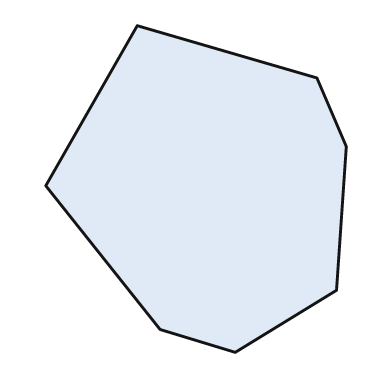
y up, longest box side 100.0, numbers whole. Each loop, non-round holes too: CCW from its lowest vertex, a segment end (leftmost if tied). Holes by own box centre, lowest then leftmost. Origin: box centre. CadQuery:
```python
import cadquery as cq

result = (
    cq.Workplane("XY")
    .moveTo(12.0, -50.0)
    .lineTo(43.0, -31.0)
    .lineTo(46.0, 13.0)
    .lineTo(37.0, 34.0)
    .lineTo(-18.0, 50.0)
    .lineTo(-46.0, 1.0)
    .lineTo(-11.0, -43.0)
    .close()
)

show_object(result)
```